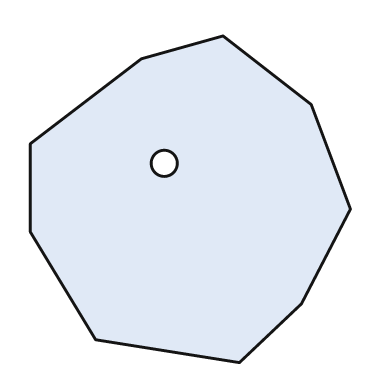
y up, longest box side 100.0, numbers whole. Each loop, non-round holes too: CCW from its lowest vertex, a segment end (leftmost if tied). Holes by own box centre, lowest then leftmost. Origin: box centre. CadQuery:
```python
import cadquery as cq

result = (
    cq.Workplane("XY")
    .moveTo(15.0, -50.0)
    .lineTo(34.0, -32.0)
    .lineTo(49.0, -3.0)
    .lineTo(37.0, 29.0)
    .lineTo(10.0, 50.0)
    .lineTo(-15.0, 43.0)
    .lineTo(-49.0, 17.0)
    .lineTo(-49.0, -10.0)
    .lineTo(-29.0, -43.0)
    .close()
    .moveTo(-8.0, 11.0)
    .circle(4.0)
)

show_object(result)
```